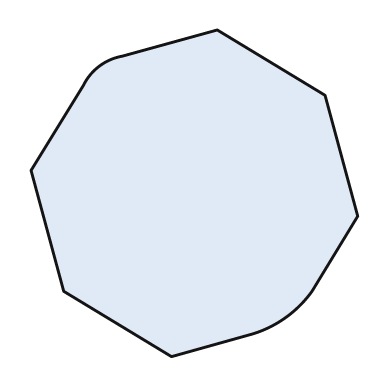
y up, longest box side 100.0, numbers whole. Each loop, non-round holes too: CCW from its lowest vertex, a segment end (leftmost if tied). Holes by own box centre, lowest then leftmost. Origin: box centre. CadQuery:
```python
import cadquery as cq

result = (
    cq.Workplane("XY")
    .moveTo(-7.0, -50.0)
    .lineTo(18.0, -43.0)
    .threePointArc((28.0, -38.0), (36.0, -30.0))
    .lineTo(50.0, -7.0)
    .lineTo(40.0, 30.0)
    .lineTo(7.0, 50.0)
    .lineTo(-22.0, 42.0)
    .threePointArc((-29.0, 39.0), (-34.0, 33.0))
    .lineTo(-50.0, 7.0)
    .lineTo(-40.0, -30.0)
    .close()
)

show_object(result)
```